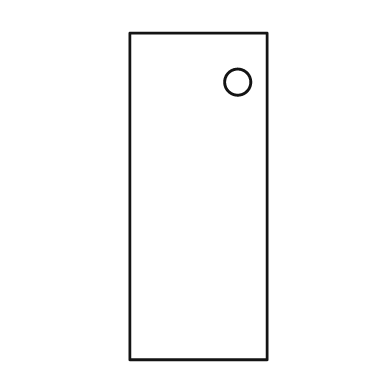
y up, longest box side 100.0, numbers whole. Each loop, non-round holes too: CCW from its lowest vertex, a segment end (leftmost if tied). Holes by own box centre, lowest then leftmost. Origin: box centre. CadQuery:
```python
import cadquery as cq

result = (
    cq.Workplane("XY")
    .moveTo(-21.0, -50.0)
    .lineTo(21.0, -50.0)
    .lineTo(21.0, 50.0)
    .lineTo(-21.0, 50.0)
    .close()
    .moveTo(12.0, 35.0)
    .circle(4.0)
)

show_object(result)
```